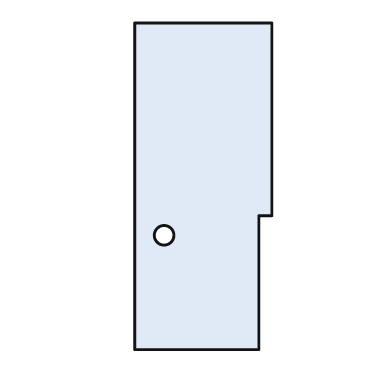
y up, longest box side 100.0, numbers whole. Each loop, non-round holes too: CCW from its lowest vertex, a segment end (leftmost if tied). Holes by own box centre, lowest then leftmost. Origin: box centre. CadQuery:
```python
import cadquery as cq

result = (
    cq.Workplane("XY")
    .moveTo(-21.0, -50.0)
    .lineTo(17.0, -50.0)
    .lineTo(17.0, -9.0)
    .lineTo(21.0, -9.0)
    .lineTo(21.0, 50.0)
    .lineTo(-21.0, 50.0)
    .close()
    .moveTo(-12.0, -15.0)
    .circle(3.0)
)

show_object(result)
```